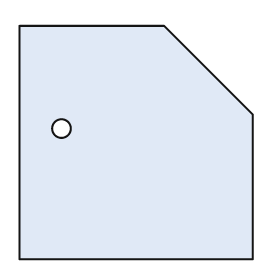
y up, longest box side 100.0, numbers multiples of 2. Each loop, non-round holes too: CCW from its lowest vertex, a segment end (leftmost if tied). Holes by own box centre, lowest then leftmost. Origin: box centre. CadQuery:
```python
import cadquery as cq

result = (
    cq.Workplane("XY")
    .moveTo(-50.0, -50.0)
    .lineTo(50.0, -50.0)
    .lineTo(50.0, 12.0)
    .lineTo(12.0, 50.0)
    .lineTo(-50.0, 50.0)
    .close()
    .moveTo(-32.0, 6.0)
    .circle(4.0)
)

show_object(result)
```